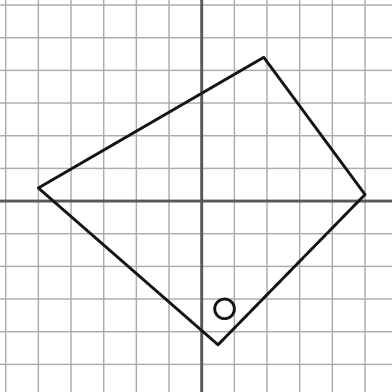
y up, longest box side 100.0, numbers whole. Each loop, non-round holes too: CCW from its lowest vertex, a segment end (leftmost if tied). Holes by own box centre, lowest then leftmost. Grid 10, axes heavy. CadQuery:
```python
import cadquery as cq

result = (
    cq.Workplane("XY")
    .moveTo(5.0, -44.0)
    .lineTo(50.0, 2.0)
    .lineTo(19.0, 44.0)
    .lineTo(-50.0, 4.0)
    .close()
    .moveTo(7.0, -33.0)
    .circle(3.0)
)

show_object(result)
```